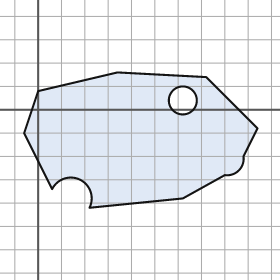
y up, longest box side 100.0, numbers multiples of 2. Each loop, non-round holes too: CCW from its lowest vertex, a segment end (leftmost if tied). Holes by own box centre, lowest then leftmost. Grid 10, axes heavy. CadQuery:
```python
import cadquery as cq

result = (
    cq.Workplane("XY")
    .moveTo(22.0, -42.0)
    .lineTo(62.0, -38.0)
    .lineTo(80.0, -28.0)
    .threePointArc((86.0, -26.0), (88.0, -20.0))
    .lineTo(94.0, -8.0)
    .lineTo(72.0, 14.0)
    .lineTo(34.0, 16.0)
    .lineTo(0.0, 8.0)
    .lineTo(-6.0, -10.0)
    .lineTo(6.0, -34.0)
    .threePointArc((18.0, -30.0), (22.0, -42.0))
    .close()
    .moveTo(62.0, 4.0)
    .circle(6.0)
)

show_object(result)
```